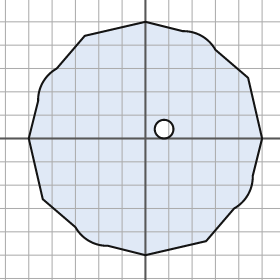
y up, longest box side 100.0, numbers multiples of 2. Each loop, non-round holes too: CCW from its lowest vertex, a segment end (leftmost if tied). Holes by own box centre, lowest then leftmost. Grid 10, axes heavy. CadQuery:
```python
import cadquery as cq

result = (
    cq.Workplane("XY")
    .moveTo(0.0, -50.0)
    .lineTo(26.0, -44.0)
    .lineTo(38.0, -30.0)
    .threePointArc((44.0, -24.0), (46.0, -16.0))
    .lineTo(50.0, 0.0)
    .lineTo(44.0, 26.0)
    .lineTo(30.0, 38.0)
    .threePointArc((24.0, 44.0), (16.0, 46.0))
    .lineTo(0.0, 50.0)
    .lineTo(-26.0, 44.0)
    .lineTo(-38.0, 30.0)
    .threePointArc((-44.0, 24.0), (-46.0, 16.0))
    .lineTo(-50.0, 0.0)
    .lineTo(-44.0, -26.0)
    .lineTo(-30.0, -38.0)
    .threePointArc((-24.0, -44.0), (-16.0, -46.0))
    .close()
    .moveTo(8.0, 4.0)
    .circle(4.0)
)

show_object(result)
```